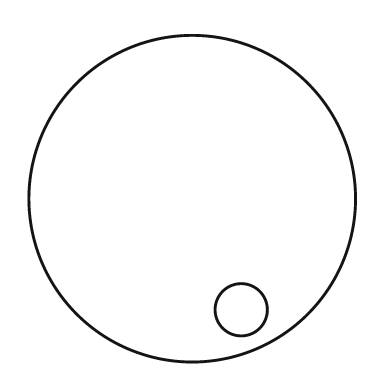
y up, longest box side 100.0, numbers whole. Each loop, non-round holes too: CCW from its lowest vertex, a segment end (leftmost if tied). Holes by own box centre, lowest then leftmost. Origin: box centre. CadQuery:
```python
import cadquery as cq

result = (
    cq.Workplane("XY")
    .moveTo(0.0, 0.0)
    .circle(50.0)
    .moveTo(15.0, -34.0)
    .circle(8.0)
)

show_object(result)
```